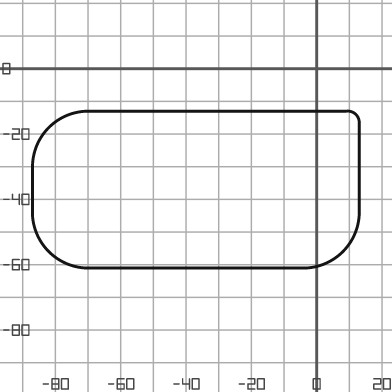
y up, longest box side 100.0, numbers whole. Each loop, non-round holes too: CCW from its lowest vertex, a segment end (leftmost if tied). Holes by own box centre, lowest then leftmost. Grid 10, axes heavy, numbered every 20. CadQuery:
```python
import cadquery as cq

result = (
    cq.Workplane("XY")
    .moveTo(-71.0, -61.0)
    .lineTo(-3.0, -61.0)
    .threePointArc((8.0, -56.0), (13.0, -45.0))
    .lineTo(13.0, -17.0)
    .threePointArc((12.0, -14.0), (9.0, -13.0))
    .lineTo(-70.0, -13.0)
    .threePointArc((-82.0, -18.0), (-87.0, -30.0))
    .lineTo(-87.0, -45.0)
    .threePointArc((-82.0, -56.0), (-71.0, -61.0))
    .close()
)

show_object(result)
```